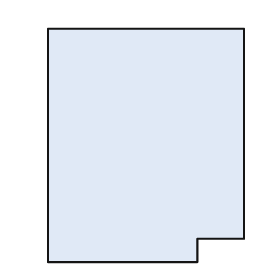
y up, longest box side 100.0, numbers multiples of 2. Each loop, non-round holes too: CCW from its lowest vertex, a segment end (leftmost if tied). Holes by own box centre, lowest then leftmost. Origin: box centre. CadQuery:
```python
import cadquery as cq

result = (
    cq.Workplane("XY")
    .moveTo(-42.0, -50.0)
    .lineTo(22.0, -50.0)
    .lineTo(22.0, -40.0)
    .lineTo(42.0, -40.0)
    .lineTo(42.0, 50.0)
    .lineTo(-42.0, 50.0)
    .close()
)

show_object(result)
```